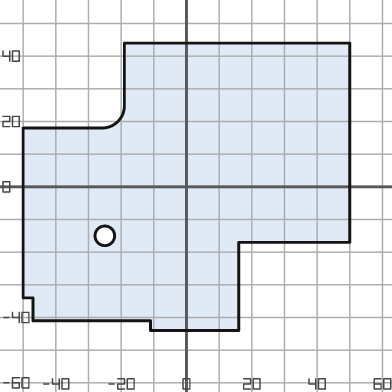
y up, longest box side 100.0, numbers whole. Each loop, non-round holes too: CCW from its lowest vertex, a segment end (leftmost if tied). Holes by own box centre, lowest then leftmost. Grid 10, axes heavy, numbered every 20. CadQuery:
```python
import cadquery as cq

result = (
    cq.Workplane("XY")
    .moveTo(-11.0, -44.0)
    .lineTo(16.0, -44.0)
    .lineTo(16.0, -17.0)
    .lineTo(50.0, -17.0)
    .lineTo(50.0, 44.0)
    .lineTo(-19.0, 44.0)
    .lineTo(-19.0, 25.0)
    .threePointArc((-21.0, 20.0), (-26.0, 18.0))
    .lineTo(-50.0, 18.0)
    .lineTo(-50.0, -34.0)
    .lineTo(-47.0, -34.0)
    .lineTo(-47.0, -41.0)
    .lineTo(-11.0, -41.0)
    .close()
    .moveTo(-25.0, -15.0)
    .circle(3.0)
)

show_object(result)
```